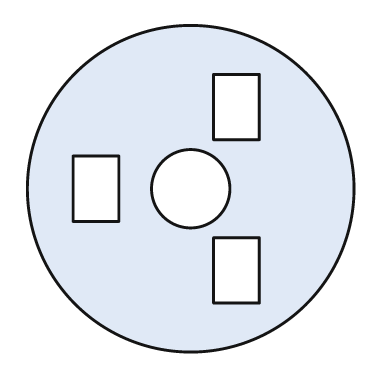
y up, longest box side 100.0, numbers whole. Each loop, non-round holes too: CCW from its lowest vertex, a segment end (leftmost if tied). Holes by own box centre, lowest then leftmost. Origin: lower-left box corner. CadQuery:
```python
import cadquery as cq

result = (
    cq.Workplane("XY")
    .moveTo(50.0, 50.0)
    .circle(50.0)
    .moveTo(57.0, 15.0)
    .lineTo(71.0, 15.0)
    .lineTo(71.0, 35.0)
    .lineTo(57.0, 35.0)
    .close()
    .moveTo(14.0, 40.0)
    .lineTo(28.0, 40.0)
    .lineTo(28.0, 60.0)
    .lineTo(14.0, 60.0)
    .close()
    .moveTo(50.0, 50.0)
    .circle(12.0)
    .moveTo(57.0, 65.0)
    .lineTo(71.0, 65.0)
    .lineTo(71.0, 85.0)
    .lineTo(57.0, 85.0)
    .close()
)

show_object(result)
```